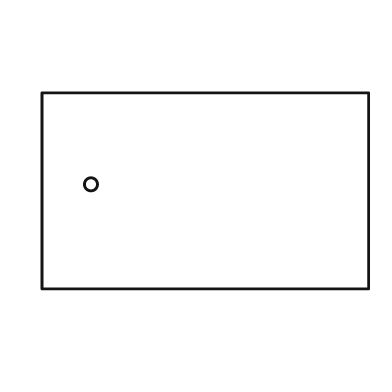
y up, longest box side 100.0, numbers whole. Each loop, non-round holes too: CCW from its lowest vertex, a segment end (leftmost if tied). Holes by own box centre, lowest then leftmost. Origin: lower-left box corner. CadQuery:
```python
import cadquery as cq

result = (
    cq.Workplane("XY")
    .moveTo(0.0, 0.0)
    .lineTo(100.0, 0.0)
    .lineTo(100.0, 60.0)
    .lineTo(0.0, 60.0)
    .close()
    .moveTo(15.0, 32.0)
    .circle(2.0)
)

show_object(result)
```